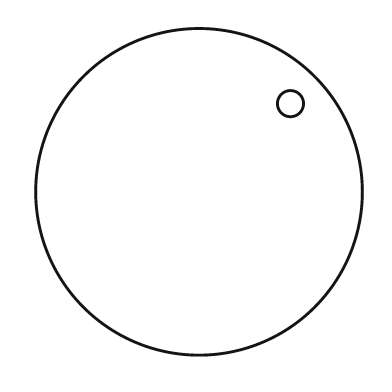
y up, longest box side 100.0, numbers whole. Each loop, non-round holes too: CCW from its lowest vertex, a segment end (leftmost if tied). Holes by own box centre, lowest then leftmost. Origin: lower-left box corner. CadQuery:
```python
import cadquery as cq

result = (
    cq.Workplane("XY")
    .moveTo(50.0, 50.0)
    .circle(50.0)
    .moveTo(78.0, 77.0)
    .circle(4.0)
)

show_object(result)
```